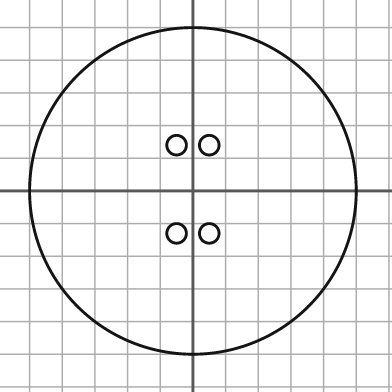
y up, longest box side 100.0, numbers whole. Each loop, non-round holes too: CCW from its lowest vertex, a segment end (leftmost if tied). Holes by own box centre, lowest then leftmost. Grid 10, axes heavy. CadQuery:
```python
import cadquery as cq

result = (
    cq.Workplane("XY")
    .moveTo(0.0, 0.0)
    .circle(50.0)
    .moveTo(-5.0, -13.0)
    .circle(3.0)
    .moveTo(5.0, -13.0)
    .circle(3.0)
    .moveTo(-5.0, 14.0)
    .circle(3.0)
    .moveTo(5.0, 14.0)
    .circle(3.0)
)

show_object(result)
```